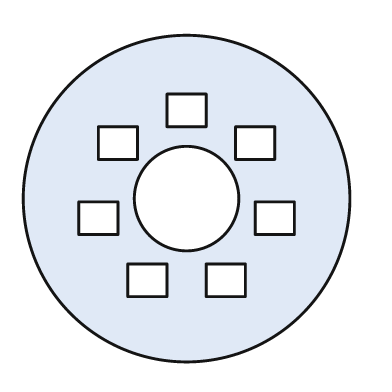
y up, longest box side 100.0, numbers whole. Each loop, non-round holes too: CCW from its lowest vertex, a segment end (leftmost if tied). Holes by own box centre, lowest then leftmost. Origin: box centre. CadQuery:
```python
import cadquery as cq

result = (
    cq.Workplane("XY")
    .moveTo(0.0, 0.0)
    .circle(50.0)
    .moveTo(-18.0, -30.0)
    .lineTo(-6.0, -30.0)
    .lineTo(-6.0, -20.0)
    .lineTo(-18.0, -20.0)
    .close()
    .moveTo(6.0, -30.0)
    .lineTo(18.0, -30.0)
    .lineTo(18.0, -20.0)
    .lineTo(6.0, -20.0)
    .close()
    .moveTo(-33.0, -11.0)
    .lineTo(-21.0, -11.0)
    .lineTo(-21.0, -1.0)
    .lineTo(-33.0, -1.0)
    .close()
    .moveTo(21.0, -11.0)
    .lineTo(33.0, -11.0)
    .lineTo(33.0, -1.0)
    .lineTo(21.0, -1.0)
    .close()
    .moveTo(0.0, 0.0)
    .circle(16.0)
    .moveTo(-27.0, 12.0)
    .lineTo(-15.0, 12.0)
    .lineTo(-15.0, 22.0)
    .lineTo(-27.0, 22.0)
    .close()
    .moveTo(15.0, 12.0)
    .lineTo(27.0, 12.0)
    .lineTo(27.0, 22.0)
    .lineTo(15.0, 22.0)
    .close()
    .moveTo(-6.0, 22.0)
    .lineTo(6.0, 22.0)
    .lineTo(6.0, 32.0)
    .lineTo(-6.0, 32.0)
    .close()
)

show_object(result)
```